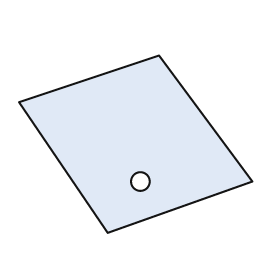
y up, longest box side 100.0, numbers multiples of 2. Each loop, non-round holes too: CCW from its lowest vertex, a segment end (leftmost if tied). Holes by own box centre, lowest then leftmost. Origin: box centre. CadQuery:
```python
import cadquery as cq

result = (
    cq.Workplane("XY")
    .moveTo(-12.0, -38.0)
    .lineTo(50.0, -16.0)
    .lineTo(10.0, 38.0)
    .lineTo(-50.0, 18.0)
    .close()
    .moveTo(2.0, -16.0)
    .circle(4.0)
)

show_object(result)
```